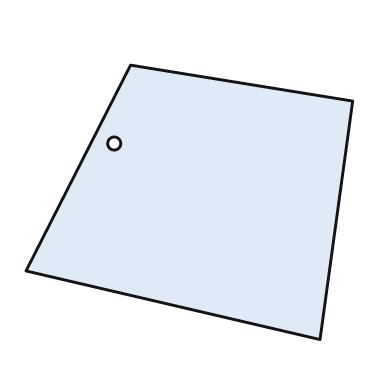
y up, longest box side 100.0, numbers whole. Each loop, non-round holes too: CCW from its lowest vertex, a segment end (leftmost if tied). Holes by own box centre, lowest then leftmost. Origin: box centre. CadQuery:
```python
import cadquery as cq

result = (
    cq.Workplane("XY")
    .moveTo(40.0, -42.0)
    .lineTo(50.0, 31.0)
    .lineTo(-18.0, 42.0)
    .lineTo(-50.0, -21.0)
    .close()
    .moveTo(-23.0, 18.0)
    .circle(2.0)
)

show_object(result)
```